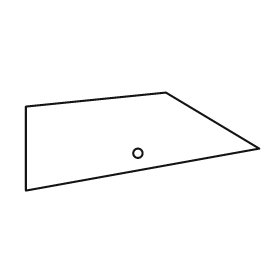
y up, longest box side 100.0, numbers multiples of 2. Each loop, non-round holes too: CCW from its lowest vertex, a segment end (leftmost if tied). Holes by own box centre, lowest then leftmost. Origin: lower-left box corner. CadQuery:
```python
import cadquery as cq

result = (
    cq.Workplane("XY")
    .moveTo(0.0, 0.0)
    .lineTo(100.0, 18.0)
    .lineTo(60.0, 42.0)
    .lineTo(0.0, 36.0)
    .close()
    .moveTo(48.0, 16.0)
    .circle(2.0)
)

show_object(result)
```